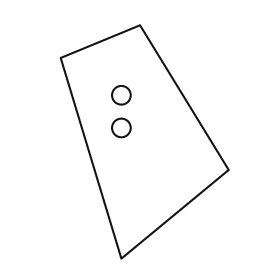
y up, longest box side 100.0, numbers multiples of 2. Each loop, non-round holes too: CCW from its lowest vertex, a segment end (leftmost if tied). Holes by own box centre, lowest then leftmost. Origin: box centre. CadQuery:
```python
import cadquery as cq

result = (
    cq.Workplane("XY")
    .moveTo(-10.0, -50.0)
    .lineTo(36.0, -12.0)
    .lineTo(-2.0, 50.0)
    .lineTo(-36.0, 36.0)
    .close()
    .moveTo(-10.0, 6.0)
    .circle(4.0)
    .moveTo(-10.0, 20.0)
    .circle(4.0)
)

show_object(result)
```